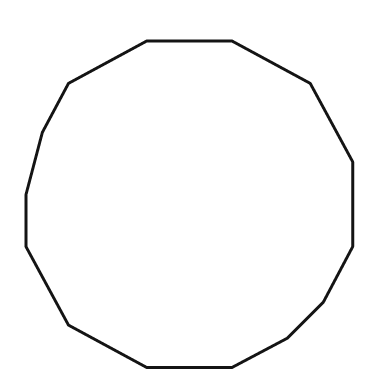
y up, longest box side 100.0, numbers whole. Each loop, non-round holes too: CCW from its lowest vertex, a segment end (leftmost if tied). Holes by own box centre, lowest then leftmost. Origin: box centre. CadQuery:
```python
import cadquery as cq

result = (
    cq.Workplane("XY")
    .moveTo(-13.0, -50.0)
    .lineTo(13.0, -50.0)
    .lineTo(30.0, -41.0)
    .lineTo(41.0, -30.0)
    .lineTo(50.0, -13.0)
    .lineTo(50.0, 13.0)
    .lineTo(37.0, 37.0)
    .lineTo(13.0, 50.0)
    .lineTo(-13.0, 50.0)
    .lineTo(-37.0, 37.0)
    .lineTo(-45.0, 22.0)
    .lineTo(-50.0, 3.0)
    .lineTo(-50.0, -13.0)
    .lineTo(-37.0, -37.0)
    .close()
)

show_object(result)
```